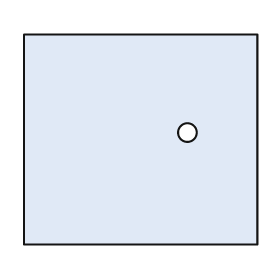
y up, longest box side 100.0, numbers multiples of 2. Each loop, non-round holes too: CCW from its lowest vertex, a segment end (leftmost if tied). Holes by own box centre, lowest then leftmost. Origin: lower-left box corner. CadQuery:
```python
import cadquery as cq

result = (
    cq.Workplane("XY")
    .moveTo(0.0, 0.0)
    .lineTo(100.0, 0.0)
    .lineTo(100.0, 90.0)
    .lineTo(0.0, 90.0)
    .close()
    .moveTo(70.0, 48.0)
    .circle(4.0)
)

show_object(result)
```